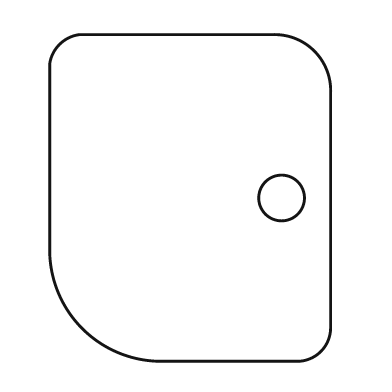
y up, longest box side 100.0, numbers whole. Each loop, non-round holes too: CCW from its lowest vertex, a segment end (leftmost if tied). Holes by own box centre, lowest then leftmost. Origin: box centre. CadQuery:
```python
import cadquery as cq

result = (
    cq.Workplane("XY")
    .moveTo(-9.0, -50.0)
    .lineTo(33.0, -50.0)
    .threePointArc((40.0, -47.0), (43.0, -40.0))
    .lineTo(43.0, 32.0)
    .threePointArc((38.0, 45.0), (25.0, 50.0))
    .lineTo(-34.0, 50.0)
    .threePointArc((-40.0, 47.0), (-43.0, 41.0))
    .lineTo(-43.0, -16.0)
    .threePointArc((-33.0, -40.0), (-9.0, -50.0))
    .close()
    .moveTo(28.0, 0.0)
    .circle(7.0)
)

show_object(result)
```